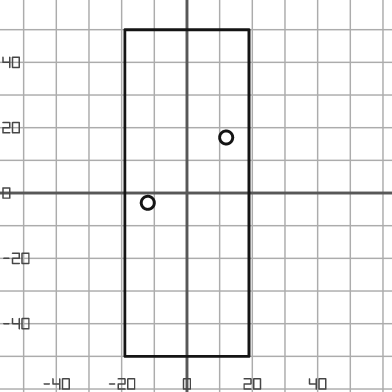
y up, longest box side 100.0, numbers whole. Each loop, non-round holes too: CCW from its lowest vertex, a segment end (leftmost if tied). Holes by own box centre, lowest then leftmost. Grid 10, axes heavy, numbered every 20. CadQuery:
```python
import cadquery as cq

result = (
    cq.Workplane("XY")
    .moveTo(-19.0, -50.0)
    .lineTo(19.0, -50.0)
    .lineTo(19.0, 50.0)
    .lineTo(-19.0, 50.0)
    .close()
    .moveTo(-12.0, -3.0)
    .circle(2.0)
    .moveTo(12.0, 17.0)
    .circle(2.0)
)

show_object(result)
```